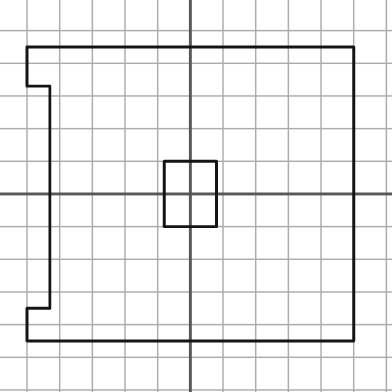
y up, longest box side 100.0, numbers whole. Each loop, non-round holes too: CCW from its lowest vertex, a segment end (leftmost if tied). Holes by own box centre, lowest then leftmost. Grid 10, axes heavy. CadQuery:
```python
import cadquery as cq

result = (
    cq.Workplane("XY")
    .moveTo(-50.0, -45.0)
    .lineTo(50.0, -45.0)
    .lineTo(50.0, 45.0)
    .lineTo(-50.0, 45.0)
    .lineTo(-50.0, 33.0)
    .lineTo(-43.0, 33.0)
    .lineTo(-43.0, -35.0)
    .lineTo(-50.0, -35.0)
    .close()
    .moveTo(-8.0, -10.0)
    .lineTo(8.0, -10.0)
    .lineTo(8.0, 10.0)
    .lineTo(-8.0, 10.0)
    .close()
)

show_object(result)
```